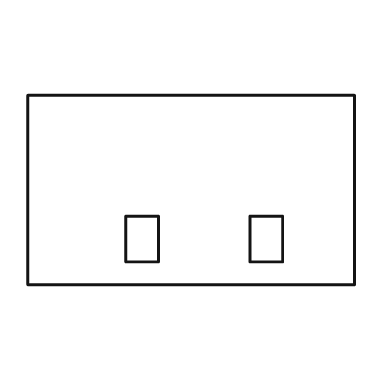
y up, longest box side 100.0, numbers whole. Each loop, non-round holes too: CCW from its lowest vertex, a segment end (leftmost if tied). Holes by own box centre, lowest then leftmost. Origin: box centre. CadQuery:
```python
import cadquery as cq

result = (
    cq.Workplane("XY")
    .moveTo(-50.0, -29.0)
    .lineTo(50.0, -29.0)
    .lineTo(50.0, 29.0)
    .lineTo(-50.0, 29.0)
    .close()
    .moveTo(-20.0, -22.0)
    .lineTo(-10.0, -22.0)
    .lineTo(-10.0, -8.0)
    .lineTo(-20.0, -8.0)
    .close()
    .moveTo(18.0, -22.0)
    .lineTo(28.0, -22.0)
    .lineTo(28.0, -8.0)
    .lineTo(18.0, -8.0)
    .close()
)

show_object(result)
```